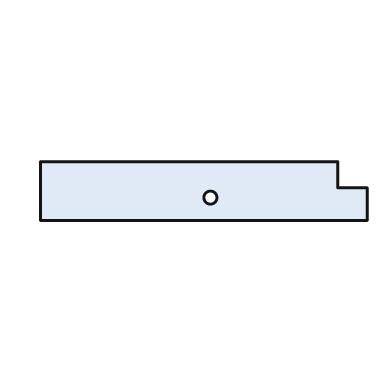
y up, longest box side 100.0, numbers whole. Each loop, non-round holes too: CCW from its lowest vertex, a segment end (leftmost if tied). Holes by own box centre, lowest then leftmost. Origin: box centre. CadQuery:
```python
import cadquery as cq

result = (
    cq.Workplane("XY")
    .moveTo(-50.0, -9.0)
    .lineTo(50.0, -9.0)
    .lineTo(50.0, 1.0)
    .lineTo(41.0, 1.0)
    .lineTo(41.0, 9.0)
    .lineTo(-50.0, 9.0)
    .close()
    .moveTo(2.0, -2.0)
    .circle(2.0)
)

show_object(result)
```